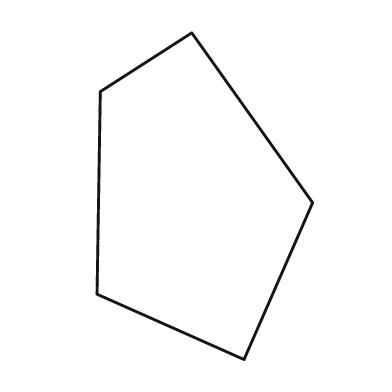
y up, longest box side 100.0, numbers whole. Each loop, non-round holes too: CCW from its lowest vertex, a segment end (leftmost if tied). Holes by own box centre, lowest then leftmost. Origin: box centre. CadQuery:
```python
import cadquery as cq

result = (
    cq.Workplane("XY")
    .moveTo(12.0, -50.0)
    .lineTo(33.0, -2.0)
    .lineTo(-4.0, 50.0)
    .lineTo(-32.0, 32.0)
    .lineTo(-33.0, -30.0)
    .close()
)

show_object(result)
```